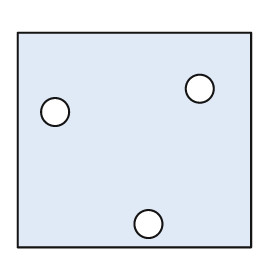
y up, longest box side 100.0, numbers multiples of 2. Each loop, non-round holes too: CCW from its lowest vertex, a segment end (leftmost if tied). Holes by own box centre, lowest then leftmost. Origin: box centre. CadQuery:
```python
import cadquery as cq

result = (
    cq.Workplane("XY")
    .moveTo(-50.0, -46.0)
    .lineTo(50.0, -46.0)
    .lineTo(50.0, 46.0)
    .lineTo(-50.0, 46.0)
    .close()
    .moveTo(6.0, -36.0)
    .circle(6.0)
    .moveTo(-34.0, 12.0)
    .circle(6.0)
    .moveTo(28.0, 22.0)
    .circle(6.0)
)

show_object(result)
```